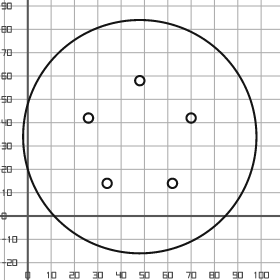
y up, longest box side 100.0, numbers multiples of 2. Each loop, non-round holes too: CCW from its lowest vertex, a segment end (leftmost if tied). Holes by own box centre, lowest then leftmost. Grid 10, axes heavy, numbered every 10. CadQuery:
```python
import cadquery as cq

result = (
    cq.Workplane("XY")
    .moveTo(48.0, 34.0)
    .circle(50.0)
    .moveTo(34.0, 14.0)
    .circle(2.0)
    .moveTo(62.0, 14.0)
    .circle(2.0)
    .moveTo(26.0, 42.0)
    .circle(2.0)
    .moveTo(70.0, 42.0)
    .circle(2.0)
    .moveTo(48.0, 58.0)
    .circle(2.0)
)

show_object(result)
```